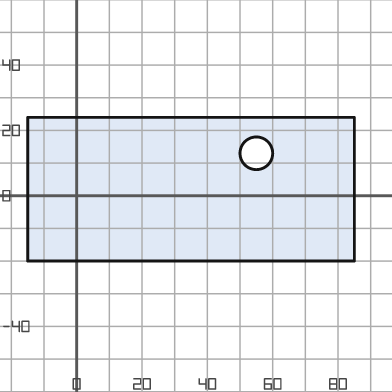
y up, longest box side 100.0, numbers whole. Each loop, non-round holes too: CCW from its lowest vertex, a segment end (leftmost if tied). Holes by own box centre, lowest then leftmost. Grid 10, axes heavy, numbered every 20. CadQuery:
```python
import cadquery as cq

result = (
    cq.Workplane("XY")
    .moveTo(-15.0, -20.0)
    .lineTo(85.0, -20.0)
    .lineTo(85.0, 24.0)
    .lineTo(-15.0, 24.0)
    .close()
    .moveTo(55.0, 13.0)
    .circle(5.0)
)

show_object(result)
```